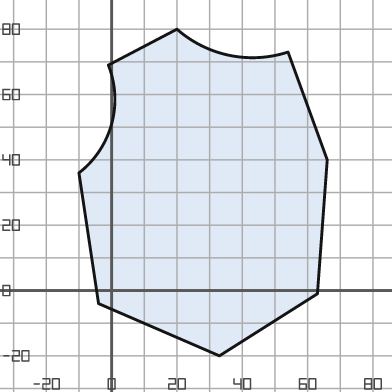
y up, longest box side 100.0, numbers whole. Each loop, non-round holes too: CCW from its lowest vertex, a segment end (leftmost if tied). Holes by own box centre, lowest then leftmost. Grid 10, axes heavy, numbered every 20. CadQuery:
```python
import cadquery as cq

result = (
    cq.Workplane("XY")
    .moveTo(33.0, -20.0)
    .lineTo(63.0, -1.0)
    .lineTo(66.0, 40.0)
    .lineTo(54.0, 73.0)
    .threePointArc((36.0, 72.0), (20.0, 80.0))
    .lineTo(-1.0, 69.0)
    .threePointArc((0.0, 51.0), (-10.0, 36.0))
    .lineTo(-4.0, -4.0)
    .close()
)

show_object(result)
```